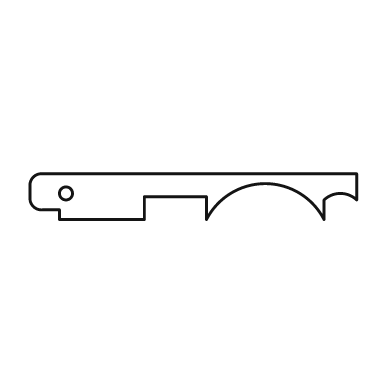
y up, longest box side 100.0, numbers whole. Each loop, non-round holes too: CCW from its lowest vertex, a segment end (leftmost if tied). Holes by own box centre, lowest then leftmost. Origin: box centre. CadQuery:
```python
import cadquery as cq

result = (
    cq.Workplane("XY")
    .moveTo(-41.0, -7.0)
    .lineTo(-15.0, -7.0)
    .lineTo(-15.0, 0.0)
    .lineTo(4.0, 0.0)
    .lineTo(4.0, -7.0)
    .threePointArc((22.0, 4.0), (40.0, -7.0))
    .lineTo(40.0, -1.0)
    .threePointArc((45.0, 1.0), (50.0, -1.0))
    .lineTo(50.0, 7.0)
    .lineTo(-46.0, 7.0)
    .threePointArc((-49.0, 6.0), (-50.0, 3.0))
    .lineTo(-50.0, 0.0)
    .threePointArc((-49.0, -3.0), (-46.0, -4.0))
    .lineTo(-41.0, -4.0)
    .close()
    .moveTo(-39.0, 1.0)
    .circle(2.0)
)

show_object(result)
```